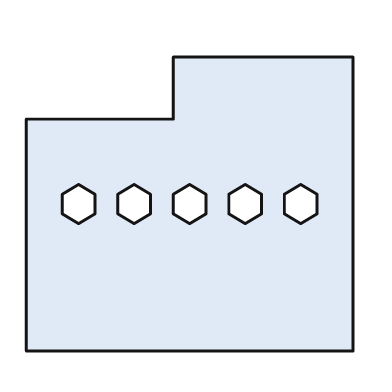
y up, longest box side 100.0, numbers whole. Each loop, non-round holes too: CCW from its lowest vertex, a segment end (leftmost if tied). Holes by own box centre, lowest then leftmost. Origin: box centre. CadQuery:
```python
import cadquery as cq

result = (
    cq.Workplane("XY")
    .moveTo(-50.0, -45.0)
    .lineTo(50.0, -45.0)
    .lineTo(50.0, 45.0)
    .lineTo(-5.0, 45.0)
    .lineTo(-5.0, 26.0)
    .lineTo(-50.0, 26.0)
    .close()
    .moveTo(-34.0, -6.0)
    .lineTo(-29.0, -3.0)
    .lineTo(-29.0, 3.0)
    .lineTo(-34.0, 6.0)
    .lineTo(-39.0, 3.0)
    .lineTo(-39.0, -3.0)
    .close()
    .moveTo(-17.0, -6.0)
    .lineTo(-12.0, -3.0)
    .lineTo(-12.0, 3.0)
    .lineTo(-17.0, 6.0)
    .lineTo(-22.0, 3.0)
    .lineTo(-22.0, -3.0)
    .close()
    .moveTo(0.0, -6.0)
    .lineTo(5.0, -3.0)
    .lineTo(5.0, 3.0)
    .lineTo(0.0, 6.0)
    .lineTo(-5.0, 3.0)
    .lineTo(-5.0, -3.0)
    .close()
    .moveTo(17.0, -6.0)
    .lineTo(22.0, -3.0)
    .lineTo(22.0, 3.0)
    .lineTo(17.0, 6.0)
    .lineTo(12.0, 3.0)
    .lineTo(12.0, -3.0)
    .close()
    .moveTo(34.0, -6.0)
    .lineTo(39.0, -3.0)
    .lineTo(39.0, 3.0)
    .lineTo(34.0, 6.0)
    .lineTo(29.0, 3.0)
    .lineTo(29.0, -3.0)
    .close()
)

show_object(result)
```